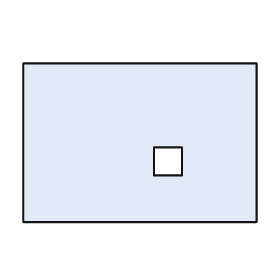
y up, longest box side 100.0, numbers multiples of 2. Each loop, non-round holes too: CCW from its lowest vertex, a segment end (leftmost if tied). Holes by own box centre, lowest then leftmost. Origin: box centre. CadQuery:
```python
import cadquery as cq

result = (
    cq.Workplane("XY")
    .moveTo(-50.0, -34.0)
    .lineTo(50.0, -34.0)
    .lineTo(50.0, 34.0)
    .lineTo(-50.0, 34.0)
    .close()
    .moveTo(6.0, -14.0)
    .lineTo(18.0, -14.0)
    .lineTo(18.0, -2.0)
    .lineTo(6.0, -2.0)
    .close()
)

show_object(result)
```